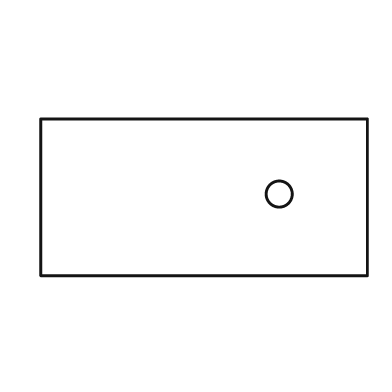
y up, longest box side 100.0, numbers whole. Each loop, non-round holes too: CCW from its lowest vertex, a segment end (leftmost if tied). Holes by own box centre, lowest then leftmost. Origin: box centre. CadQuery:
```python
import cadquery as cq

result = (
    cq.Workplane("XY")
    .moveTo(-50.0, -24.0)
    .lineTo(50.0, -24.0)
    .lineTo(50.0, 24.0)
    .lineTo(-50.0, 24.0)
    .close()
    .moveTo(23.0, 1.0)
    .circle(4.0)
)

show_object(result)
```